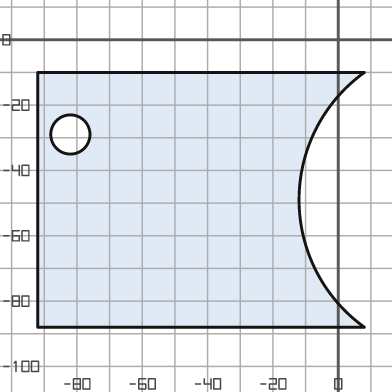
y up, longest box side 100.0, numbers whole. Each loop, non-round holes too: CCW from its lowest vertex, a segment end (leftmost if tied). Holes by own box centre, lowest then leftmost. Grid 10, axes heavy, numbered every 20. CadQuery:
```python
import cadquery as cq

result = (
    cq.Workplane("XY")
    .moveTo(-92.0, -88.0)
    .lineTo(8.0, -88.0)
    .threePointArc((-12.0, -49.0), (8.0, -10.0))
    .lineTo(-92.0, -10.0)
    .close()
    .moveTo(-82.0, -29.0)
    .circle(6.0)
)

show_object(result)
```